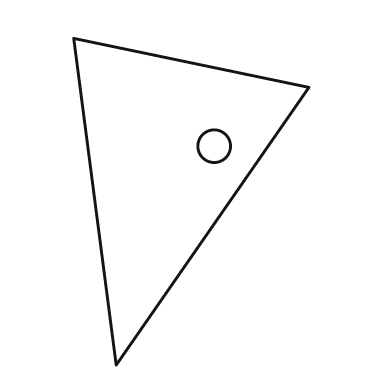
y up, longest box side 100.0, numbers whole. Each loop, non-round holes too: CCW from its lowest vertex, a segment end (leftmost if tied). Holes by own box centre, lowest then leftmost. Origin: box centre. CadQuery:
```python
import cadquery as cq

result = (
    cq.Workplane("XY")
    .moveTo(-23.0, -50.0)
    .lineTo(36.0, 35.0)
    .lineTo(-36.0, 50.0)
    .close()
    .moveTo(7.0, 17.0)
    .circle(5.0)
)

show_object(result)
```